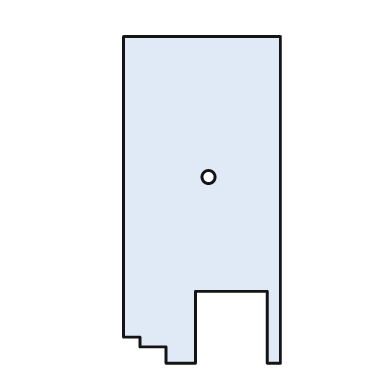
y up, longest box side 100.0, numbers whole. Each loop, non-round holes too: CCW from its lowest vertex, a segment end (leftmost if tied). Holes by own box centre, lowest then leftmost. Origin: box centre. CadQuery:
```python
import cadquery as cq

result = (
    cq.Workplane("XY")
    .moveTo(-11.0, -50.0)
    .lineTo(-2.0, -50.0)
    .lineTo(-2.0, -28.0)
    .lineTo(20.0, -28.0)
    .lineTo(20.0, -50.0)
    .lineTo(24.0, -50.0)
    .lineTo(24.0, 50.0)
    .lineTo(-24.0, 50.0)
    .lineTo(-24.0, -42.0)
    .lineTo(-19.0, -42.0)
    .lineTo(-19.0, -45.0)
    .lineTo(-11.0, -45.0)
    .close()
    .moveTo(2.0, 7.0)
    .circle(2.0)
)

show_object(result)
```